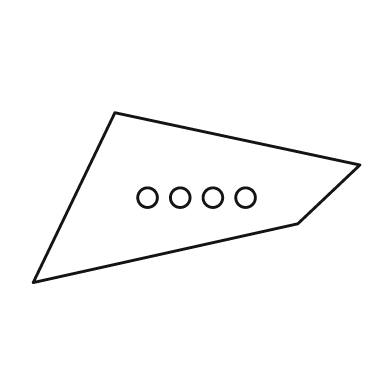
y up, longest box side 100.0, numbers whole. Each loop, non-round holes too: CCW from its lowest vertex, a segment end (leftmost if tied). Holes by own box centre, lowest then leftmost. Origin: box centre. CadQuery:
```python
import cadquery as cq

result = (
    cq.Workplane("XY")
    .moveTo(-50.0, -26.0)
    .lineTo(31.0, -8.0)
    .lineTo(50.0, 10.0)
    .lineTo(-25.0, 26.0)
    .close()
    .moveTo(-15.0, 0.0)
    .circle(3.0)
    .moveTo(-5.0, 0.0)
    .circle(3.0)
    .moveTo(5.0, 0.0)
    .circle(3.0)
    .moveTo(15.0, 0.0)
    .circle(3.0)
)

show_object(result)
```